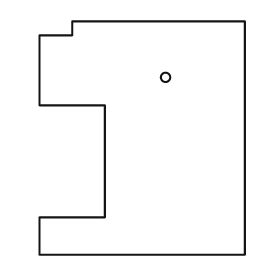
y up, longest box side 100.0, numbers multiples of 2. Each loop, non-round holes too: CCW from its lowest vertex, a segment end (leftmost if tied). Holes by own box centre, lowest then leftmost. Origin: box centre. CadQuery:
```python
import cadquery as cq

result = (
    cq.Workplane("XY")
    .moveTo(-44.0, -50.0)
    .lineTo(44.0, -50.0)
    .lineTo(44.0, 50.0)
    .lineTo(-30.0, 50.0)
    .lineTo(-30.0, 44.0)
    .lineTo(-44.0, 44.0)
    .lineTo(-44.0, 14.0)
    .lineTo(-16.0, 14.0)
    .lineTo(-16.0, -34.0)
    .lineTo(-44.0, -34.0)
    .close()
    .moveTo(10.0, 26.0)
    .circle(2.0)
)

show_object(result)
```